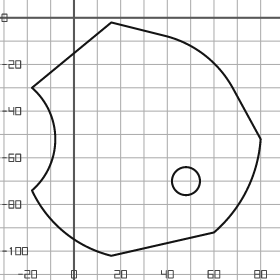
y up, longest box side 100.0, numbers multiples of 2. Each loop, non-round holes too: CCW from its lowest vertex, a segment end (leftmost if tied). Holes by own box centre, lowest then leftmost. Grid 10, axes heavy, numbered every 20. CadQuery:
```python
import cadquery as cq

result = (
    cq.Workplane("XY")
    .moveTo(16.0, -102.0)
    .lineTo(60.0, -92.0)
    .threePointArc((74.0, -74.0), (80.0, -52.0))
    .lineTo(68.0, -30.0)
    .threePointArc((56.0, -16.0), (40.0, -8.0))
    .lineTo(16.0, -2.0)
    .lineTo(-18.0, -30.0)
    .threePointArc((-8.0, -52.0), (-18.0, -74.0))
    .threePointArc((-4.0, -92.0), (16.0, -102.0))
    .close()
    .moveTo(48.0, -70.0)
    .circle(6.0)
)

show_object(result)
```